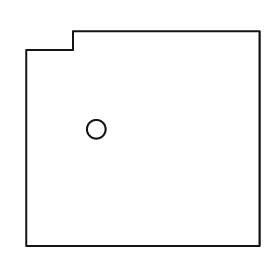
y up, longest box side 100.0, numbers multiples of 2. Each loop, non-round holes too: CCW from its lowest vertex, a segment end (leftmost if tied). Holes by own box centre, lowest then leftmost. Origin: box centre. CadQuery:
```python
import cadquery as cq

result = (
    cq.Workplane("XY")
    .moveTo(-50.0, -46.0)
    .lineTo(50.0, -46.0)
    .lineTo(50.0, 46.0)
    .lineTo(-30.0, 46.0)
    .lineTo(-30.0, 38.0)
    .lineTo(-50.0, 38.0)
    .close()
    .moveTo(-20.0, 4.0)
    .circle(4.0)
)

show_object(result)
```